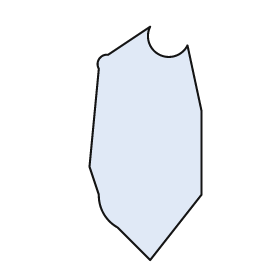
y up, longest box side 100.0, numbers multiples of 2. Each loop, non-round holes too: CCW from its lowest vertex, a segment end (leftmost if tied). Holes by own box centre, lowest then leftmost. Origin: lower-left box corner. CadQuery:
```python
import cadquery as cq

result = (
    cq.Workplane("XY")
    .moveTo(26.0, 0.0)
    .lineTo(48.0, 28.0)
    .lineTo(48.0, 64.0)
    .lineTo(42.0, 92.0)
    .threePointArc((30.0, 88.0), (26.0, 100.0))
    .lineTo(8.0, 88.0)
    .threePointArc((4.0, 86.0), (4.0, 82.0))
    .lineTo(0.0, 40.0)
    .lineTo(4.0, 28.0)
    .threePointArc((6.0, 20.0), (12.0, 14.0))
    .close()
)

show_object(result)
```